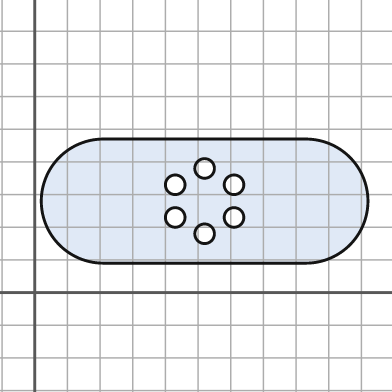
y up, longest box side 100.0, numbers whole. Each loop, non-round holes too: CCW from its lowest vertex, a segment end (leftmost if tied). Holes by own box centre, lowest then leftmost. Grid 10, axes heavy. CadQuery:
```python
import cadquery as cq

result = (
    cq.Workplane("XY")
    .moveTo(21.0, 9.0)
    .lineTo(83.0, 9.0)
    .threePointArc((102.0, 28.0), (83.0, 47.0))
    .lineTo(21.0, 47.0)
    .threePointArc((2.0, 28.0), (21.0, 9.0))
    .close()
    .moveTo(52.0, 18.0)
    .circle(3.0)
    .moveTo(43.0, 23.0)
    .circle(3.0)
    .moveTo(61.0, 23.0)
    .circle(3.0)
    .moveTo(43.0, 33.0)
    .circle(3.0)
    .moveTo(61.0, 33.0)
    .circle(3.0)
    .moveTo(52.0, 38.0)
    .circle(3.0)
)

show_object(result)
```